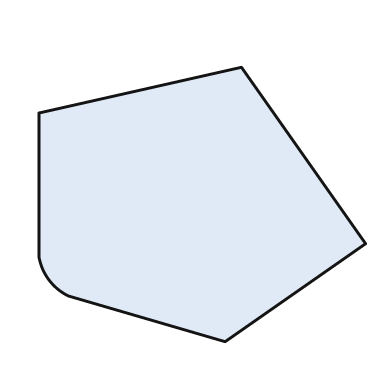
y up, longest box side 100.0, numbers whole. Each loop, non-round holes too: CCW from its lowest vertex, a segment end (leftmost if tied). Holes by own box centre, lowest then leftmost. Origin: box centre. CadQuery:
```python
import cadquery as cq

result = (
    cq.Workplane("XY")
    .moveTo(7.0, -42.0)
    .lineTo(50.0, -12.0)
    .lineTo(12.0, 42.0)
    .lineTo(-50.0, 28.0)
    .lineTo(-50.0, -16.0)
    .threePointArc((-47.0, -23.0), (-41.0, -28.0))
    .close()
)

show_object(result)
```